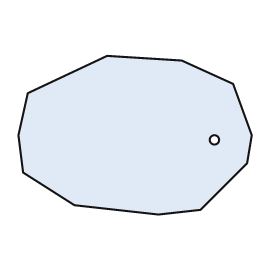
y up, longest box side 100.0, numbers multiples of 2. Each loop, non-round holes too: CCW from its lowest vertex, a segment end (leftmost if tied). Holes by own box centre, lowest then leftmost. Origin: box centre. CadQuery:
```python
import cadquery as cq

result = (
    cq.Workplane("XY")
    .moveTo(10.0, -34.0)
    .lineTo(28.0, -32.0)
    .lineTo(48.0, -12.0)
    .lineTo(50.0, 0.0)
    .lineTo(42.0, 22.0)
    .lineTo(20.0, 32.0)
    .lineTo(-12.0, 34.0)
    .lineTo(-46.0, 18.0)
    .lineTo(-50.0, 0.0)
    .lineTo(-48.0, -16.0)
    .lineTo(-26.0, -30.0)
    .close()
    .moveTo(34.0, -2.0)
    .circle(2.0)
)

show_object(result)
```